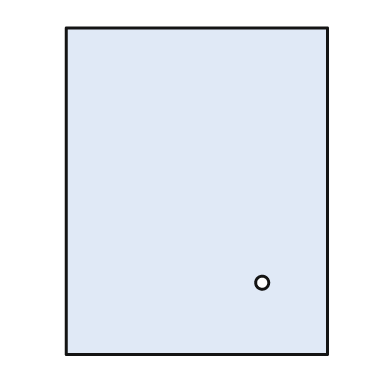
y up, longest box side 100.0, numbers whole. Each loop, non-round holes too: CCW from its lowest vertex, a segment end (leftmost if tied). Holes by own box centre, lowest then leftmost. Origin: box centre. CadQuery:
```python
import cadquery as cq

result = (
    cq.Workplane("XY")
    .moveTo(-40.0, -50.0)
    .lineTo(40.0, -50.0)
    .lineTo(40.0, 50.0)
    .lineTo(-40.0, 50.0)
    .close()
    .moveTo(20.0, -28.0)
    .circle(2.0)
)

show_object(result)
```